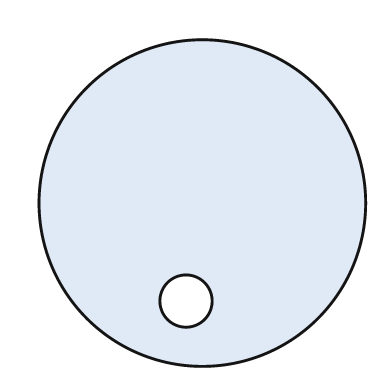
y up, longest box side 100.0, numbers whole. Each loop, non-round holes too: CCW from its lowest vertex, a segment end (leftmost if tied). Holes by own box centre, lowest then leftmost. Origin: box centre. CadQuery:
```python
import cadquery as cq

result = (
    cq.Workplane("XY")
    .moveTo(0.0, 0.0)
    .circle(50.0)
    .moveTo(-5.0, -30.0)
    .circle(8.0)
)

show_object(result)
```